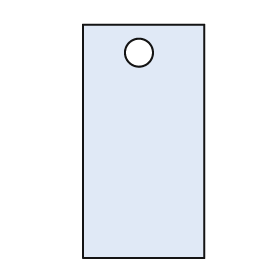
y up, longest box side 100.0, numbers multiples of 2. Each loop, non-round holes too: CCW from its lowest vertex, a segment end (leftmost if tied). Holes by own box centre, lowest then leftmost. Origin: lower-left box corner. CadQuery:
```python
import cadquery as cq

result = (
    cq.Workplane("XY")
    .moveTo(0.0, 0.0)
    .lineTo(52.0, 0.0)
    .lineTo(52.0, 100.0)
    .lineTo(0.0, 100.0)
    .close()
    .moveTo(24.0, 88.0)
    .circle(6.0)
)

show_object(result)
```